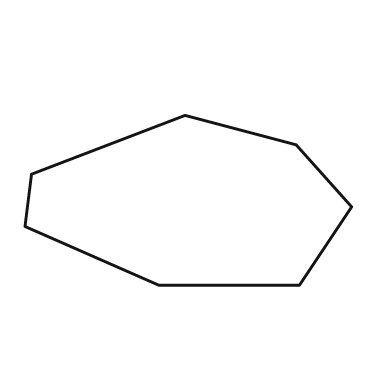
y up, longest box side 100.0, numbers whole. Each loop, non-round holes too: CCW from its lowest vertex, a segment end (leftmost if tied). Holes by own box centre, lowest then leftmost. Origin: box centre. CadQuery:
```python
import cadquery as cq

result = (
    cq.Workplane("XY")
    .moveTo(-9.0, -26.0)
    .lineTo(34.0, -26.0)
    .lineTo(50.0, -2.0)
    .lineTo(33.0, 17.0)
    .lineTo(-1.0, 26.0)
    .lineTo(-48.0, 8.0)
    .lineTo(-50.0, -8.0)
    .close()
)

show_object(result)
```